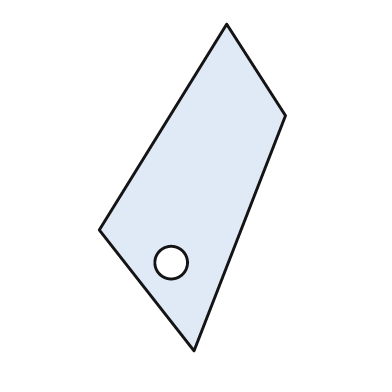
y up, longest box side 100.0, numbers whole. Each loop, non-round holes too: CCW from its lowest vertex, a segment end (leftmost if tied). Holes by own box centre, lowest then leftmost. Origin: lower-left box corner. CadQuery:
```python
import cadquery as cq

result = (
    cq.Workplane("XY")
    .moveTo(29.0, 0.0)
    .lineTo(57.0, 72.0)
    .lineTo(39.0, 100.0)
    .lineTo(0.0, 37.0)
    .close()
    .moveTo(22.0, 27.0)
    .circle(5.0)
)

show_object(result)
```